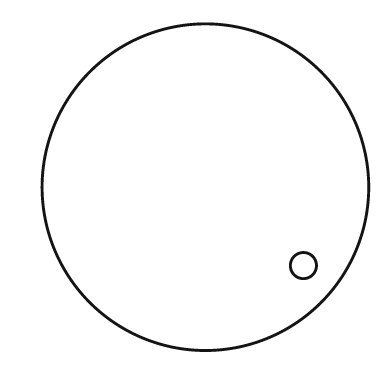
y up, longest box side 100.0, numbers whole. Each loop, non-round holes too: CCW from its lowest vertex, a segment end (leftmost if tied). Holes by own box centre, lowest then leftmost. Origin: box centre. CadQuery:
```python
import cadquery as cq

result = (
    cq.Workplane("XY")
    .moveTo(0.0, 0.0)
    .circle(50.0)
    .moveTo(30.0, -24.0)
    .circle(4.0)
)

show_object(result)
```